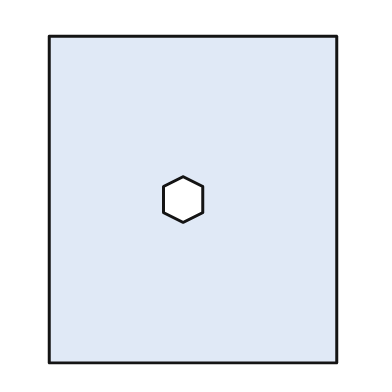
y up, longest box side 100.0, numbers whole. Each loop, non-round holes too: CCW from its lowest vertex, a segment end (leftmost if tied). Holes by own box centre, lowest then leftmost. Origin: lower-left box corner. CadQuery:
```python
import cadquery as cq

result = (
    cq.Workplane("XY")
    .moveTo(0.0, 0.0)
    .lineTo(88.0, 0.0)
    .lineTo(88.0, 100.0)
    .lineTo(0.0, 100.0)
    .close()
    .moveTo(41.0, 43.0)
    .lineTo(47.0, 46.0)
    .lineTo(47.0, 54.0)
    .lineTo(41.0, 57.0)
    .lineTo(35.0, 54.0)
    .lineTo(35.0, 46.0)
    .close()
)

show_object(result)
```